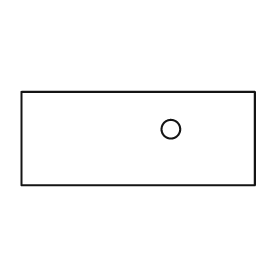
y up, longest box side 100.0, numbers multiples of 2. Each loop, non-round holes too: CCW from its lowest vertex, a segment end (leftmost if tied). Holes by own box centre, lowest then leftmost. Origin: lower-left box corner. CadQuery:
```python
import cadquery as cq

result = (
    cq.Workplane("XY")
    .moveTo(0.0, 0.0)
    .lineTo(100.0, 0.0)
    .lineTo(100.0, 40.0)
    .lineTo(0.0, 40.0)
    .close()
    .moveTo(64.0, 24.0)
    .circle(4.0)
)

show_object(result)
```